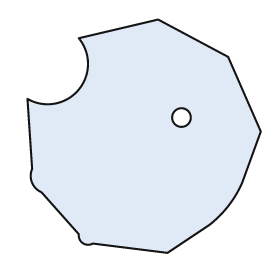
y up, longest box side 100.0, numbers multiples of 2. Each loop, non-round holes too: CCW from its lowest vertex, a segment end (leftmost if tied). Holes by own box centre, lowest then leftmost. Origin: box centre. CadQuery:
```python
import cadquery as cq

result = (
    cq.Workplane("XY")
    .moveTo(10.0, -50.0)
    .lineTo(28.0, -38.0)
    .threePointArc((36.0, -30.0), (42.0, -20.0))
    .lineTo(50.0, 2.0)
    .lineTo(36.0, 34.0)
    .lineTo(6.0, 50.0)
    .lineTo(-28.0, 42.0)
    .threePointArc((-28.0, 20.0), (-50.0, 16.0))
    .lineTo(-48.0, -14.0)
    .threePointArc((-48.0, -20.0), (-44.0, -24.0))
    .lineTo(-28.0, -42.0)
    .threePointArc((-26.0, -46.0), (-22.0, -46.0))
    .close()
    .moveTo(16.0, 8.0)
    .circle(4.0)
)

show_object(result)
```